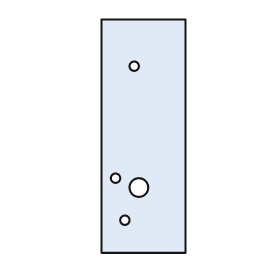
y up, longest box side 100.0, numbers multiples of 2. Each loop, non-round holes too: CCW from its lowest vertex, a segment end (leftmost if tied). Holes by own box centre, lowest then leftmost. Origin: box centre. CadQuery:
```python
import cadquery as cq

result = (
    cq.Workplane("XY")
    .moveTo(-18.0, -50.0)
    .lineTo(18.0, -50.0)
    .lineTo(18.0, 50.0)
    .lineTo(-18.0, 50.0)
    .close()
    .moveTo(-8.0, -36.0)
    .circle(2.0)
    .moveTo(-2.0, -22.0)
    .circle(4.0)
    .moveTo(-12.0, -18.0)
    .circle(2.0)
    .moveTo(-4.0, 30.0)
    .circle(2.0)
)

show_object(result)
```